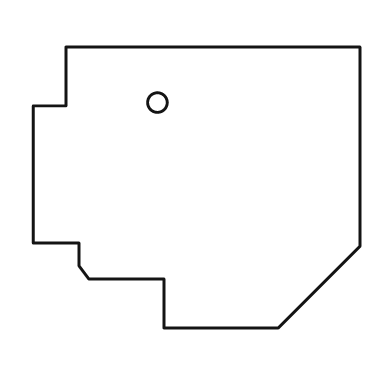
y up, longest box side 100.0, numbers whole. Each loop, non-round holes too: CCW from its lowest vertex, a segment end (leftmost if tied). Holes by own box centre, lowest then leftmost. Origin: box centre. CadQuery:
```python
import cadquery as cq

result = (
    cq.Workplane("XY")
    .moveTo(-10.0, -43.0)
    .lineTo(25.0, -43.0)
    .lineTo(50.0, -18.0)
    .lineTo(50.0, 43.0)
    .lineTo(-40.0, 43.0)
    .lineTo(-40.0, 25.0)
    .lineTo(-50.0, 25.0)
    .lineTo(-50.0, -17.0)
    .lineTo(-36.0, -17.0)
    .lineTo(-36.0, -24.0)
    .lineTo(-33.0, -28.0)
    .lineTo(-10.0, -28.0)
    .close()
    .moveTo(-12.0, 26.0)
    .circle(3.0)
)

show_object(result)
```